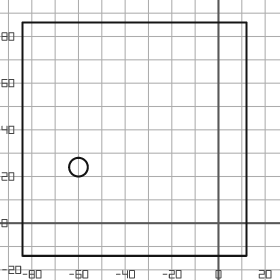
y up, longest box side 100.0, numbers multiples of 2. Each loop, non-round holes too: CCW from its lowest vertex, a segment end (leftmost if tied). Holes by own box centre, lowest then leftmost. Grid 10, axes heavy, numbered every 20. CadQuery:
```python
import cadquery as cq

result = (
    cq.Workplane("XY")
    .moveTo(-84.0, -14.0)
    .lineTo(12.0, -14.0)
    .lineTo(12.0, 86.0)
    .lineTo(-84.0, 86.0)
    .close()
    .moveTo(-60.0, 24.0)
    .circle(4.0)
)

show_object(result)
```